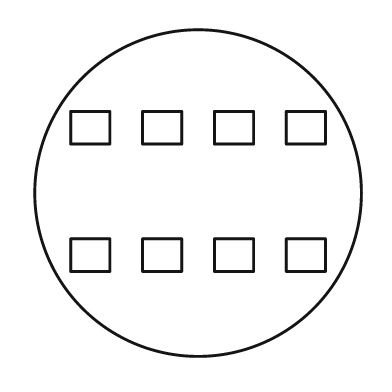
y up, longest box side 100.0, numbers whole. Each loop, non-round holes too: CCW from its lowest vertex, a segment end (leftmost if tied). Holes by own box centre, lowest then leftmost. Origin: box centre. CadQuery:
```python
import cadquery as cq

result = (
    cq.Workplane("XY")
    .moveTo(0.0, 0.0)
    .circle(50.0)
    .moveTo(-39.0, -24.0)
    .lineTo(-27.0, -24.0)
    .lineTo(-27.0, -14.0)
    .lineTo(-39.0, -14.0)
    .close()
    .moveTo(-17.0, -24.0)
    .lineTo(-5.0, -24.0)
    .lineTo(-5.0, -14.0)
    .lineTo(-17.0, -14.0)
    .close()
    .moveTo(5.0, -24.0)
    .lineTo(17.0, -24.0)
    .lineTo(17.0, -14.0)
    .lineTo(5.0, -14.0)
    .close()
    .moveTo(27.0, -24.0)
    .lineTo(39.0, -24.0)
    .lineTo(39.0, -14.0)
    .lineTo(27.0, -14.0)
    .close()
    .moveTo(-39.0, 15.0)
    .lineTo(-27.0, 15.0)
    .lineTo(-27.0, 25.0)
    .lineTo(-39.0, 25.0)
    .close()
    .moveTo(-17.0, 15.0)
    .lineTo(-5.0, 15.0)
    .lineTo(-5.0, 25.0)
    .lineTo(-17.0, 25.0)
    .close()
    .moveTo(5.0, 15.0)
    .lineTo(17.0, 15.0)
    .lineTo(17.0, 25.0)
    .lineTo(5.0, 25.0)
    .close()
    .moveTo(27.0, 15.0)
    .lineTo(39.0, 15.0)
    .lineTo(39.0, 25.0)
    .lineTo(27.0, 25.0)
    .close()
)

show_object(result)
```